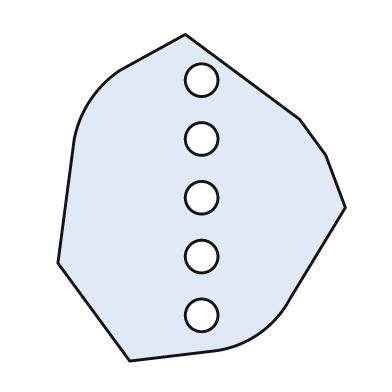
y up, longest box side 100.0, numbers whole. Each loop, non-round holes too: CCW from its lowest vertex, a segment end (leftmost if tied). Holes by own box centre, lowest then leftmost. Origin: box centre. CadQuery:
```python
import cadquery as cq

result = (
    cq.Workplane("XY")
    .moveTo(-22.0, -50.0)
    .lineTo(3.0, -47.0)
    .threePointArc((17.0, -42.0), (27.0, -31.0))
    .lineTo(44.0, -3.0)
    .lineTo(38.0, 13.0)
    .lineTo(30.0, 24.0)
    .lineTo(-5.0, 50.0)
    .lineTo(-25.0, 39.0)
    .threePointArc((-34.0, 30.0), (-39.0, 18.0))
    .lineTo(-44.0, -20.0)
    .close()
    .moveTo(0.0, -36.0)
    .circle(5.0)
    .moveTo(0.0, -18.0)
    .circle(5.0)
    .moveTo(0.0, 0.0)
    .circle(5.0)
    .moveTo(0.0, 18.0)
    .circle(5.0)
    .moveTo(0.0, 36.0)
    .circle(5.0)
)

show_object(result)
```